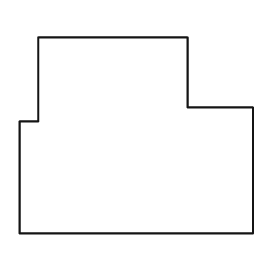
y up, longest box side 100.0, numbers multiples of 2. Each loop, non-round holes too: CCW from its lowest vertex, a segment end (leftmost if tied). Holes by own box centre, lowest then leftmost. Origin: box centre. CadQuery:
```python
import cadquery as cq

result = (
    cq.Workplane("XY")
    .moveTo(-50.0, -42.0)
    .lineTo(50.0, -42.0)
    .lineTo(50.0, 12.0)
    .lineTo(22.0, 12.0)
    .lineTo(22.0, 42.0)
    .lineTo(-42.0, 42.0)
    .lineTo(-42.0, 6.0)
    .lineTo(-50.0, 6.0)
    .close()
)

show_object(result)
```